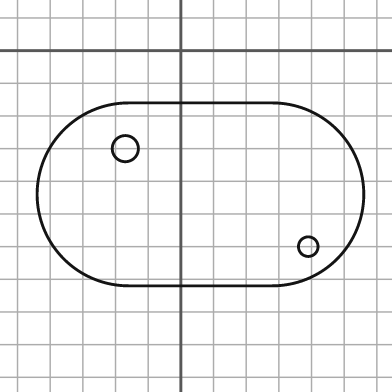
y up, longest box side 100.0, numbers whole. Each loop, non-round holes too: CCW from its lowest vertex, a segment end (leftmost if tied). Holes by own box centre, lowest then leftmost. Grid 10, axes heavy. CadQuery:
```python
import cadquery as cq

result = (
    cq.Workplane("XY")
    .moveTo(-16.0, -72.0)
    .lineTo(28.0, -72.0)
    .threePointArc((56.0, -44.0), (28.0, -16.0))
    .lineTo(-16.0, -16.0)
    .threePointArc((-44.0, -44.0), (-16.0, -72.0))
    .close()
    .moveTo(39.0, -60.0)
    .circle(3.0)
    .moveTo(-17.0, -30.0)
    .circle(4.0)
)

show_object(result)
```